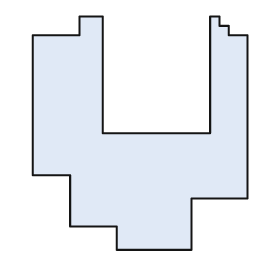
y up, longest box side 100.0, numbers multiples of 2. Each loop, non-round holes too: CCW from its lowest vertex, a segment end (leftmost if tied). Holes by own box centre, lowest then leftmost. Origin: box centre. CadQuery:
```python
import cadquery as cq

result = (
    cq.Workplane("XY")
    .moveTo(-10.0, -50.0)
    .lineTo(22.0, -50.0)
    .lineTo(22.0, -28.0)
    .lineTo(46.0, -28.0)
    .lineTo(46.0, 42.0)
    .lineTo(38.0, 42.0)
    .lineTo(38.0, 46.0)
    .lineTo(34.0, 46.0)
    .lineTo(34.0, 50.0)
    .lineTo(30.0, 50.0)
    .lineTo(30.0, 0.0)
    .lineTo(-16.0, 0.0)
    .lineTo(-16.0, 50.0)
    .lineTo(-26.0, 50.0)
    .lineTo(-26.0, 42.0)
    .lineTo(-46.0, 42.0)
    .lineTo(-46.0, -18.0)
    .lineTo(-30.0, -18.0)
    .lineTo(-30.0, -40.0)
    .lineTo(-10.0, -40.0)
    .close()
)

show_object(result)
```